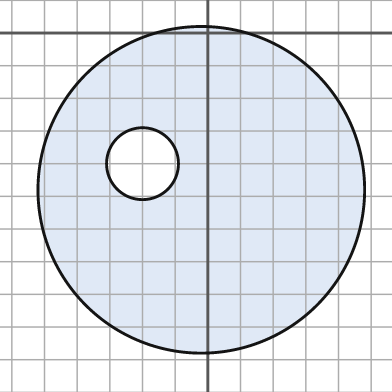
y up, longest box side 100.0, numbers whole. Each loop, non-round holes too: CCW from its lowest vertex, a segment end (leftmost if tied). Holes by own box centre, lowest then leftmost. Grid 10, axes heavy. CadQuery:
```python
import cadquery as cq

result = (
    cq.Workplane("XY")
    .moveTo(-2.0, -48.0)
    .circle(50.0)
    .moveTo(-20.0, -40.0)
    .circle(11.0)
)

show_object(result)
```